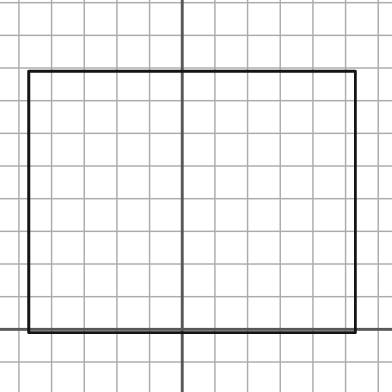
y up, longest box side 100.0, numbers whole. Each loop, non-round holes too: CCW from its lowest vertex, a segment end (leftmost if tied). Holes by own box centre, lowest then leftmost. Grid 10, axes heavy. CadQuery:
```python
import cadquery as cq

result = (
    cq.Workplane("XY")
    .moveTo(-47.0, -1.0)
    .lineTo(53.0, -1.0)
    .lineTo(53.0, 79.0)
    .lineTo(-47.0, 79.0)
    .close()
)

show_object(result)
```